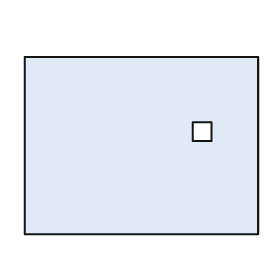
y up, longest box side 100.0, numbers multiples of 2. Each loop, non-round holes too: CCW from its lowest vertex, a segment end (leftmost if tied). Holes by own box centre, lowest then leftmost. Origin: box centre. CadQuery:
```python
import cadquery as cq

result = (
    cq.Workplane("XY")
    .moveTo(-50.0, -38.0)
    .lineTo(50.0, -38.0)
    .lineTo(50.0, 38.0)
    .lineTo(-50.0, 38.0)
    .close()
    .moveTo(22.0, 2.0)
    .lineTo(30.0, 2.0)
    .lineTo(30.0, 10.0)
    .lineTo(22.0, 10.0)
    .close()
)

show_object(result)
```